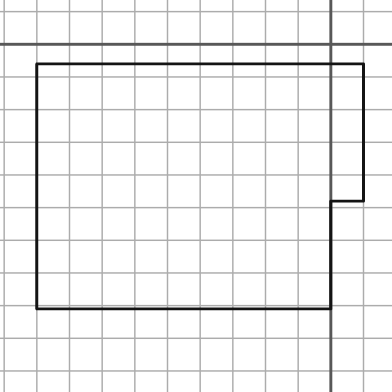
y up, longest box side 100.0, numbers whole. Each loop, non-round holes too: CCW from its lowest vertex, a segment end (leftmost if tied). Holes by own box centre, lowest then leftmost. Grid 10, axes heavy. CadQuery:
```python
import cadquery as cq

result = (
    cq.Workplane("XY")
    .moveTo(-90.0, -81.0)
    .lineTo(0.0, -81.0)
    .lineTo(0.0, -48.0)
    .lineTo(10.0, -48.0)
    .lineTo(10.0, -6.0)
    .lineTo(-90.0, -6.0)
    .close()
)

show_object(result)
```